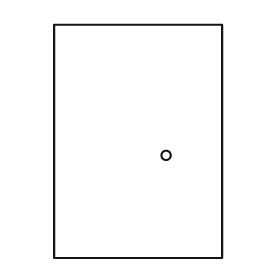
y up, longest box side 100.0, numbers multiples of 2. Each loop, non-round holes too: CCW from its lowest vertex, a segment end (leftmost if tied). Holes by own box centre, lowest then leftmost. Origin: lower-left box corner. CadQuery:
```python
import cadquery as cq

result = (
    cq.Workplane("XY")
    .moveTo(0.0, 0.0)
    .lineTo(72.0, 0.0)
    .lineTo(72.0, 100.0)
    .lineTo(0.0, 100.0)
    .close()
    .moveTo(48.0, 44.0)
    .circle(2.0)
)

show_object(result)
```